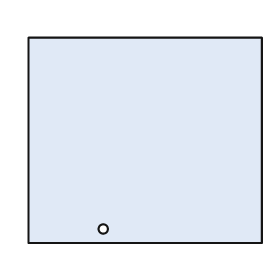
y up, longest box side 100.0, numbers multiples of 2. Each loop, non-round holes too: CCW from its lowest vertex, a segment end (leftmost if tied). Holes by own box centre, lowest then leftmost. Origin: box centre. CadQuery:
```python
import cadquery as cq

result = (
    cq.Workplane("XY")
    .moveTo(-50.0, -44.0)
    .lineTo(50.0, -44.0)
    .lineTo(50.0, 44.0)
    .lineTo(-50.0, 44.0)
    .close()
    .moveTo(-18.0, -38.0)
    .circle(2.0)
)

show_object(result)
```